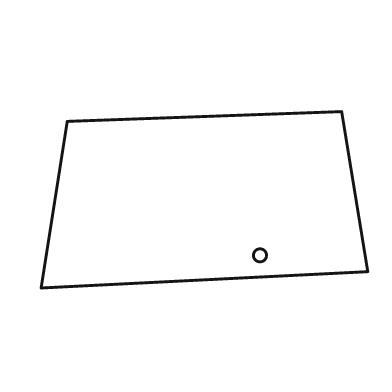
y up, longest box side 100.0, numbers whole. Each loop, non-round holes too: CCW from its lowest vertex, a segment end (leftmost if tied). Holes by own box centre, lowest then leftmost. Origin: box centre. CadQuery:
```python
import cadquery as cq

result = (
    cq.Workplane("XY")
    .moveTo(-50.0, -27.0)
    .lineTo(50.0, -22.0)
    .lineTo(42.0, 27.0)
    .lineTo(-42.0, 24.0)
    .close()
    .moveTo(17.0, -17.0)
    .circle(2.0)
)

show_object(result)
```